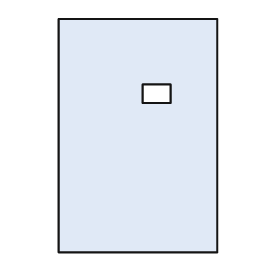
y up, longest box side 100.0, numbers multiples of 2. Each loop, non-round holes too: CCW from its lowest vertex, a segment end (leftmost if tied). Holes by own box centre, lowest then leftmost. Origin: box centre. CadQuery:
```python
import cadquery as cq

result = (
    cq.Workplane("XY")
    .moveTo(-34.0, -50.0)
    .lineTo(34.0, -50.0)
    .lineTo(34.0, 50.0)
    .lineTo(-34.0, 50.0)
    .close()
    .moveTo(2.0, 14.0)
    .lineTo(14.0, 14.0)
    .lineTo(14.0, 22.0)
    .lineTo(2.0, 22.0)
    .close()
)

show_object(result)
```